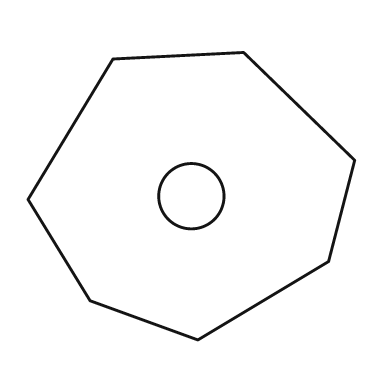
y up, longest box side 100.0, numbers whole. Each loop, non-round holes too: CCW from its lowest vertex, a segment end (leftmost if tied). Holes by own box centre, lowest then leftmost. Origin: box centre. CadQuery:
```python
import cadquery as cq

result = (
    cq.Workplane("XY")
    .moveTo(2.0, -44.0)
    .lineTo(42.0, -20.0)
    .lineTo(50.0, 11.0)
    .lineTo(16.0, 44.0)
    .lineTo(-24.0, 42.0)
    .lineTo(-50.0, -1.0)
    .lineTo(-31.0, -32.0)
    .close()
    .moveTo(0.0, 0.0)
    .circle(10.0)
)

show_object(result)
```